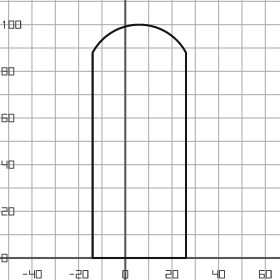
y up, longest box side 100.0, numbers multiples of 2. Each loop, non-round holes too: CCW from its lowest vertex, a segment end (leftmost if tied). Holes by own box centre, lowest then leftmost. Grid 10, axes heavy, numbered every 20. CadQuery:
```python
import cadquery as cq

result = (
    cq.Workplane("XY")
    .moveTo(-14.0, 0.0)
    .lineTo(26.0, 0.0)
    .lineTo(26.0, 88.0)
    .threePointArc((6.0, 100.0), (-14.0, 88.0))
    .close()
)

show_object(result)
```